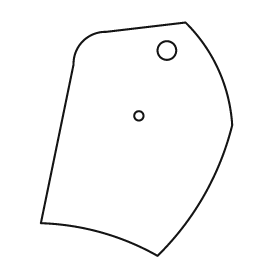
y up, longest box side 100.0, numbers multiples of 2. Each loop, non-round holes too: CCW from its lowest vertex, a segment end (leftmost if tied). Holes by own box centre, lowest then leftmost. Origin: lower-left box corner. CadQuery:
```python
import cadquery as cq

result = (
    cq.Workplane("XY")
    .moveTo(50.0, 0.0)
    .threePointArc((70.0, 26.0), (82.0, 56.0))
    .threePointArc((76.0, 80.0), (62.0, 100.0))
    .lineTo(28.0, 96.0)
    .threePointArc((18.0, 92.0), (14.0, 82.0))
    .lineTo(0.0, 14.0)
    .threePointArc((26.0, 10.0), (50.0, 0.0))
    .close()
    .moveTo(42.0, 60.0)
    .circle(2.0)
    .moveTo(54.0, 88.0)
    .circle(4.0)
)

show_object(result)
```